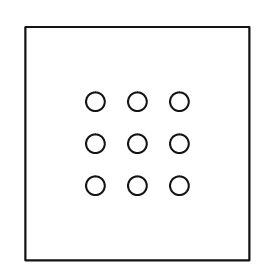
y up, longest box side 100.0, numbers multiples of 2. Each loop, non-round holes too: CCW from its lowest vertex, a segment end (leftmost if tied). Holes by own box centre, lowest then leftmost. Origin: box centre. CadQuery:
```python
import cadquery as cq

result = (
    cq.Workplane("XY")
    .moveTo(-48.0, -50.0)
    .lineTo(48.0, -50.0)
    .lineTo(48.0, 50.0)
    .lineTo(-48.0, 50.0)
    .close()
    .moveTo(-18.0, -18.0)
    .circle(4.0)
    .moveTo(0.0, -18.0)
    .circle(4.0)
    .moveTo(18.0, -18.0)
    .circle(4.0)
    .moveTo(-18.0, 0.0)
    .circle(4.0)
    .moveTo(0.0, 0.0)
    .circle(4.0)
    .moveTo(18.0, 0.0)
    .circle(4.0)
    .moveTo(-18.0, 18.0)
    .circle(4.0)
    .moveTo(0.0, 18.0)
    .circle(4.0)
    .moveTo(18.0, 18.0)
    .circle(4.0)
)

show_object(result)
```